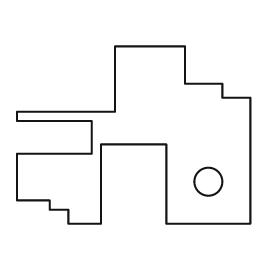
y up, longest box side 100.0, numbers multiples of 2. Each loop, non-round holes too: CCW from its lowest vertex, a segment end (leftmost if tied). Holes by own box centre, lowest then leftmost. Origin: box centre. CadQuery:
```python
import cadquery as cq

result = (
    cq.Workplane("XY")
    .moveTo(-28.0, -38.0)
    .lineTo(-14.0, -38.0)
    .lineTo(-14.0, -4.0)
    .lineTo(14.0, -4.0)
    .lineTo(14.0, -38.0)
    .lineTo(50.0, -38.0)
    .lineTo(50.0, 16.0)
    .lineTo(38.0, 16.0)
    .lineTo(38.0, 22.0)
    .lineTo(22.0, 22.0)
    .lineTo(22.0, 38.0)
    .lineTo(-8.0, 38.0)
    .lineTo(-8.0, 10.0)
    .lineTo(-50.0, 10.0)
    .lineTo(-50.0, 6.0)
    .lineTo(-18.0, 6.0)
    .lineTo(-18.0, -8.0)
    .lineTo(-50.0, -8.0)
    .lineTo(-50.0, -28.0)
    .lineTo(-36.0, -28.0)
    .lineTo(-36.0, -32.0)
    .lineTo(-28.0, -32.0)
    .close()
    .moveTo(32.0, -20.0)
    .circle(6.0)
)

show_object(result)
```